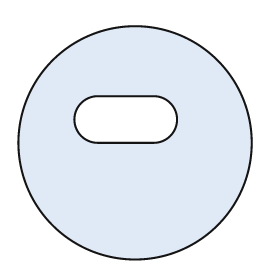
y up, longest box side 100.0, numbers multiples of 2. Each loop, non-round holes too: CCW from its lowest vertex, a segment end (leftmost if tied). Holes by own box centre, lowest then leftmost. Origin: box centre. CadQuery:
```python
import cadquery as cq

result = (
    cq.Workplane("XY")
    .moveTo(0.0, 0.0)
    .circle(50.0)
    .moveTo(-16.0, 0.0)
    .lineTo(8.0, 0.0)
    .threePointArc((18.0, 10.0), (8.0, 20.0))
    .lineTo(-16.0, 20.0)
    .threePointArc((-26.0, 10.0), (-16.0, 0.0))
    .close()
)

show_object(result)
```